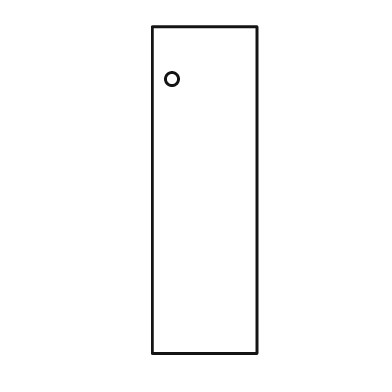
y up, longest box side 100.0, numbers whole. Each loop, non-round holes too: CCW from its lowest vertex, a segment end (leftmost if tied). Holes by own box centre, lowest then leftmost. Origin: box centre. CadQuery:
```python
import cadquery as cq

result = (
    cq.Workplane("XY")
    .moveTo(-16.0, -50.0)
    .lineTo(16.0, -50.0)
    .lineTo(16.0, 50.0)
    .lineTo(-16.0, 50.0)
    .close()
    .moveTo(-10.0, 34.0)
    .circle(2.0)
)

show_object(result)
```